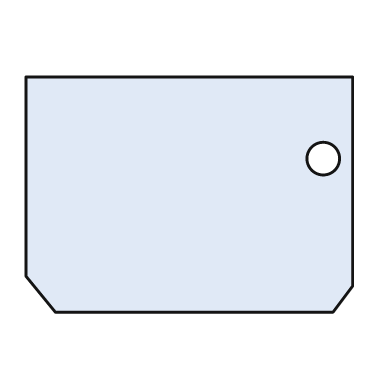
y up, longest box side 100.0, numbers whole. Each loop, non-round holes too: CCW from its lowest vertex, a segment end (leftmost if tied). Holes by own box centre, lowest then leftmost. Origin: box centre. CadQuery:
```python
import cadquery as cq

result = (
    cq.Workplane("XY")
    .moveTo(-41.0, -36.0)
    .lineTo(44.0, -36.0)
    .lineTo(50.0, -28.0)
    .lineTo(50.0, 36.0)
    .lineTo(-50.0, 36.0)
    .lineTo(-50.0, -25.0)
    .close()
    .moveTo(41.0, 11.0)
    .circle(5.0)
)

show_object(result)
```